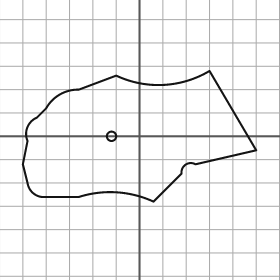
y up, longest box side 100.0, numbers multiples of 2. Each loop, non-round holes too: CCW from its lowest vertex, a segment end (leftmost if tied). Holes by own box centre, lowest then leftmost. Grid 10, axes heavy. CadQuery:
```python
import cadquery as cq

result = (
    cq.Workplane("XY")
    .moveTo(6.0, -28.0)
    .lineTo(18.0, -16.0)
    .threePointArc((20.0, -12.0), (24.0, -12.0))
    .lineTo(50.0, -6.0)
    .lineTo(30.0, 28.0)
    .threePointArc((10.0, 22.0), (-10.0, 26.0))
    .lineTo(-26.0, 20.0)
    .threePointArc((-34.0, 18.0), (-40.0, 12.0))
    .lineTo(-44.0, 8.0)
    .threePointArc((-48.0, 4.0), (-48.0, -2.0))
    .lineTo(-50.0, -12.0)
    .lineTo(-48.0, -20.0)
    .threePointArc((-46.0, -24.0), (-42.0, -26.0))
    .lineTo(-26.0, -26.0)
    .threePointArc((-10.0, -24.0), (6.0, -28.0))
    .close()
    .moveTo(-12.0, 0.0)
    .circle(2.0)
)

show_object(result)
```